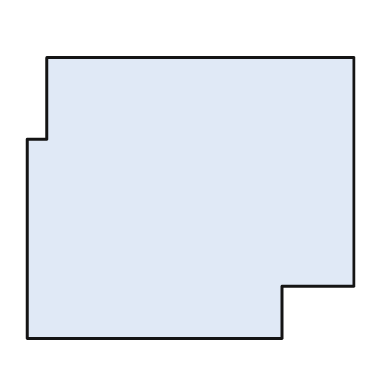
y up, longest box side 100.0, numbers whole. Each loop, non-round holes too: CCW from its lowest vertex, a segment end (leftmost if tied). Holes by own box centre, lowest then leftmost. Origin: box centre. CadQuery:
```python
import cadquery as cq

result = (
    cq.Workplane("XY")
    .moveTo(-50.0, -43.0)
    .lineTo(28.0, -43.0)
    .lineTo(28.0, -27.0)
    .lineTo(50.0, -27.0)
    .lineTo(50.0, 43.0)
    .lineTo(-44.0, 43.0)
    .lineTo(-44.0, 18.0)
    .lineTo(-50.0, 18.0)
    .close()
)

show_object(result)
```